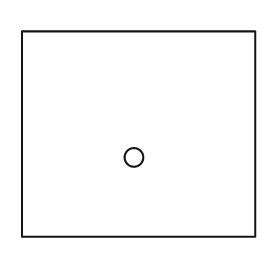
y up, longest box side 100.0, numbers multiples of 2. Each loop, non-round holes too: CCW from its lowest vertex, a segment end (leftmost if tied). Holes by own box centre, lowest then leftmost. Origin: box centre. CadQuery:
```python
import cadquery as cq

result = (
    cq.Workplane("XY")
    .moveTo(-50.0, -44.0)
    .lineTo(50.0, -44.0)
    .lineTo(50.0, 44.0)
    .lineTo(-50.0, 44.0)
    .close()
    .moveTo(-2.0, -10.0)
    .circle(4.0)
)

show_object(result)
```